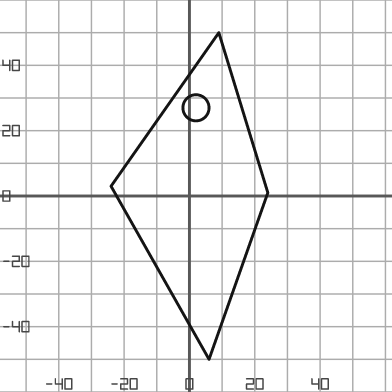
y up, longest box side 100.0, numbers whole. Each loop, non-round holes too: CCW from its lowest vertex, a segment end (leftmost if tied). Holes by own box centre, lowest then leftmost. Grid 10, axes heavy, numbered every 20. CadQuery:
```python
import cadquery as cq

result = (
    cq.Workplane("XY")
    .moveTo(6.0, -50.0)
    .lineTo(24.0, 1.0)
    .lineTo(9.0, 50.0)
    .lineTo(-24.0, 3.0)
    .close()
    .moveTo(2.0, 27.0)
    .circle(4.0)
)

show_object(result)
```